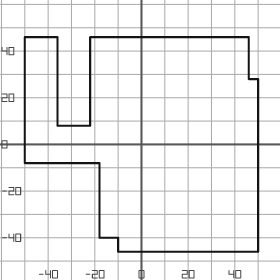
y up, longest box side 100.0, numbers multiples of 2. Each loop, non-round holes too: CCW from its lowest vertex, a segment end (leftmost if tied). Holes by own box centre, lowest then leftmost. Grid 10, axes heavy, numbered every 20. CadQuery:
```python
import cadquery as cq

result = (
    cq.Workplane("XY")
    .moveTo(-10.0, -46.0)
    .lineTo(50.0, -46.0)
    .lineTo(50.0, 28.0)
    .lineTo(46.0, 28.0)
    .lineTo(46.0, 46.0)
    .lineTo(-22.0, 46.0)
    .lineTo(-22.0, 8.0)
    .lineTo(-36.0, 8.0)
    .lineTo(-36.0, 46.0)
    .lineTo(-50.0, 46.0)
    .lineTo(-50.0, -8.0)
    .lineTo(-18.0, -8.0)
    .lineTo(-18.0, -40.0)
    .lineTo(-10.0, -40.0)
    .close()
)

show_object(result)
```